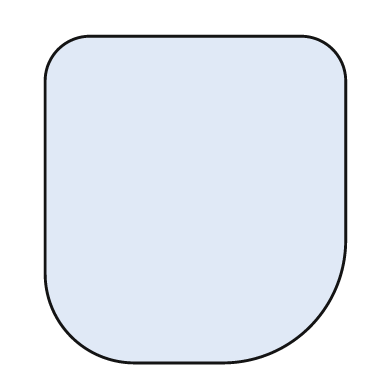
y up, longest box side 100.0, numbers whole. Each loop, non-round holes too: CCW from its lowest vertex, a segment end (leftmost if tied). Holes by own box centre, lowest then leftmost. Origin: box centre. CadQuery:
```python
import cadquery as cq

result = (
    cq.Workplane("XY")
    .moveTo(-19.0, -50.0)
    .lineTo(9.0, -50.0)
    .threePointArc((35.0, -39.0), (46.0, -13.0))
    .lineTo(46.0, 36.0)
    .threePointArc((42.0, 46.0), (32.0, 50.0))
    .lineTo(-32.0, 50.0)
    .threePointArc((-42.0, 46.0), (-46.0, 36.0))
    .lineTo(-46.0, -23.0)
    .threePointArc((-38.0, -42.0), (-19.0, -50.0))
    .close()
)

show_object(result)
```